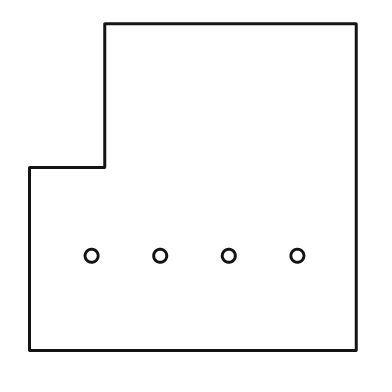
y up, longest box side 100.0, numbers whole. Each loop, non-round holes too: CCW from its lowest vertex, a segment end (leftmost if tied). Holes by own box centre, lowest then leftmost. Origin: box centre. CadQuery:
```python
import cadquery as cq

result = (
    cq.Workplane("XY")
    .moveTo(-50.0, -50.0)
    .lineTo(50.0, -50.0)
    .lineTo(50.0, 50.0)
    .lineTo(-27.0, 50.0)
    .lineTo(-27.0, 6.0)
    .lineTo(-50.0, 6.0)
    .close()
    .moveTo(-31.0, -21.0)
    .circle(2.0)
    .moveTo(-10.0, -21.0)
    .circle(2.0)
    .moveTo(11.0, -21.0)
    .circle(2.0)
    .moveTo(32.0, -21.0)
    .circle(2.0)
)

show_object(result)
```